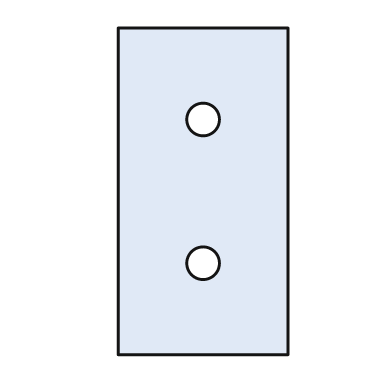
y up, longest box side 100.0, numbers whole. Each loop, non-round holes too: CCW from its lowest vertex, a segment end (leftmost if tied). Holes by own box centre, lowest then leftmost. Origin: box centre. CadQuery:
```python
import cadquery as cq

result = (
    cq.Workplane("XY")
    .moveTo(-26.0, -50.0)
    .lineTo(26.0, -50.0)
    .lineTo(26.0, 50.0)
    .lineTo(-26.0, 50.0)
    .close()
    .moveTo(0.0, -22.0)
    .circle(5.0)
    .moveTo(0.0, 22.0)
    .circle(5.0)
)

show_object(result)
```